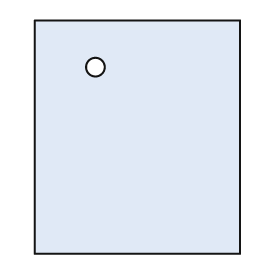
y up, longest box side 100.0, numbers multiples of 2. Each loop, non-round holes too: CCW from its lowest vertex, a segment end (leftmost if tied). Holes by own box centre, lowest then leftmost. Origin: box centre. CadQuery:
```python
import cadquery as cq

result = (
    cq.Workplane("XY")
    .moveTo(-44.0, -50.0)
    .lineTo(44.0, -50.0)
    .lineTo(44.0, 50.0)
    .lineTo(-44.0, 50.0)
    .close()
    .moveTo(-18.0, 30.0)
    .circle(4.0)
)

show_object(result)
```